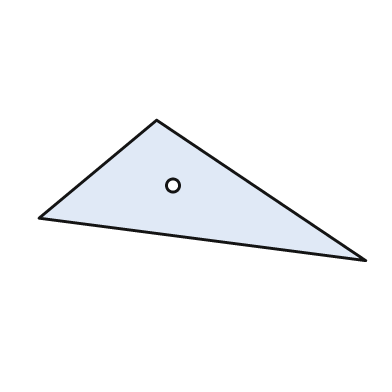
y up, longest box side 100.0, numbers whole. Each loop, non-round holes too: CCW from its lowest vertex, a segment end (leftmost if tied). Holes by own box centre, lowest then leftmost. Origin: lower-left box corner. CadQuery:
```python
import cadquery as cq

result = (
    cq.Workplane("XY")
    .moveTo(100.0, 0.0)
    .lineTo(36.0, 43.0)
    .lineTo(0.0, 13.0)
    .close()
    .moveTo(41.0, 23.0)
    .circle(2.0)
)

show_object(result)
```